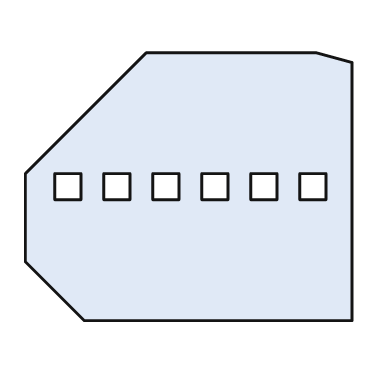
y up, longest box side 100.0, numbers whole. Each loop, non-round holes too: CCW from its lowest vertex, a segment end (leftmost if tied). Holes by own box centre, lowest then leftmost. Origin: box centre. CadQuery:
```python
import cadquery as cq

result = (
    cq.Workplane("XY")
    .moveTo(-32.0, -41.0)
    .lineTo(50.0, -41.0)
    .lineTo(50.0, 38.0)
    .lineTo(39.0, 41.0)
    .lineTo(-13.0, 41.0)
    .lineTo(-50.0, 4.0)
    .lineTo(-50.0, -23.0)
    .close()
    .moveTo(-41.0, -4.0)
    .lineTo(-33.0, -4.0)
    .lineTo(-33.0, 4.0)
    .lineTo(-41.0, 4.0)
    .close()
    .moveTo(-26.0, -4.0)
    .lineTo(-18.0, -4.0)
    .lineTo(-18.0, 4.0)
    .lineTo(-26.0, 4.0)
    .close()
    .moveTo(-11.0, -4.0)
    .lineTo(-3.0, -4.0)
    .lineTo(-3.0, 4.0)
    .lineTo(-11.0, 4.0)
    .close()
    .moveTo(4.0, -4.0)
    .lineTo(12.0, -4.0)
    .lineTo(12.0, 4.0)
    .lineTo(4.0, 4.0)
    .close()
    .moveTo(19.0, -4.0)
    .lineTo(27.0, -4.0)
    .lineTo(27.0, 4.0)
    .lineTo(19.0, 4.0)
    .close()
    .moveTo(34.0, -4.0)
    .lineTo(42.0, -4.0)
    .lineTo(42.0, 4.0)
    .lineTo(34.0, 4.0)
    .close()
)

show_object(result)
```